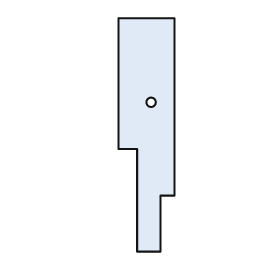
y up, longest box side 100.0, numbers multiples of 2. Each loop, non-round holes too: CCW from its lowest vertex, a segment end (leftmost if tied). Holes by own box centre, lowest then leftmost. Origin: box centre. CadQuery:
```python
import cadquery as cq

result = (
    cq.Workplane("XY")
    .moveTo(-4.0, -50.0)
    .lineTo(6.0, -50.0)
    .lineTo(6.0, -26.0)
    .lineTo(12.0, -26.0)
    .lineTo(12.0, 50.0)
    .lineTo(-12.0, 50.0)
    .lineTo(-12.0, -6.0)
    .lineTo(-4.0, -6.0)
    .close()
    .moveTo(2.0, 14.0)
    .circle(2.0)
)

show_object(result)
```